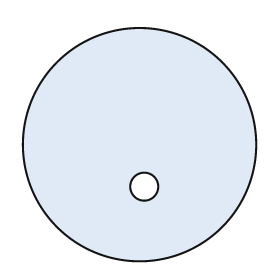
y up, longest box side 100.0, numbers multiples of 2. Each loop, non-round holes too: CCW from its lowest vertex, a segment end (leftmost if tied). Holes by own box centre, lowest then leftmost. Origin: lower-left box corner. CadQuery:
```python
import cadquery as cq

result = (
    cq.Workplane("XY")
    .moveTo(50.0, 50.0)
    .circle(50.0)
    .moveTo(52.0, 32.0)
    .circle(6.0)
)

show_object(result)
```